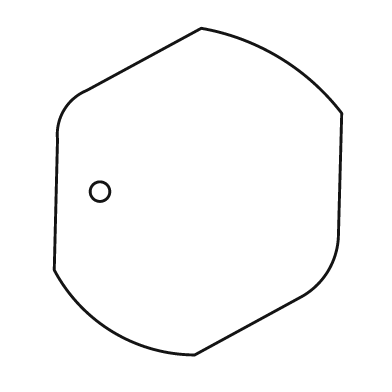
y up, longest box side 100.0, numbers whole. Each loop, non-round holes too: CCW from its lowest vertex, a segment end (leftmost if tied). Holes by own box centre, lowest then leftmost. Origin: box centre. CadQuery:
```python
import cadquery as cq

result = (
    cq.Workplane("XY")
    .moveTo(-1.0, -50.0)
    .lineTo(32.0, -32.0)
    .threePointArc((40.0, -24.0), (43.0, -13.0))
    .lineTo(44.0, 24.0)
    .threePointArc((25.0, 41.0), (1.0, 50.0))
    .lineTo(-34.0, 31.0)
    .threePointArc((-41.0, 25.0), (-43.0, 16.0))
    .lineTo(-44.0, -24.0)
    .threePointArc((-26.0, -43.0), (-1.0, -50.0))
    .close()
    .moveTo(-30.0, 0.0)
    .circle(3.0)
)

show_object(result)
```